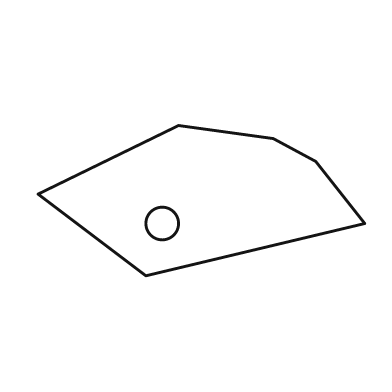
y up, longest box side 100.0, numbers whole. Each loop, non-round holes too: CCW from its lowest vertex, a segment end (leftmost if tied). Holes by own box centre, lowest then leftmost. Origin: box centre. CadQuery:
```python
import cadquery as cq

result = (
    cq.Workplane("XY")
    .moveTo(-17.0, -23.0)
    .lineTo(50.0, -7.0)
    .lineTo(35.0, 12.0)
    .lineTo(22.0, 19.0)
    .lineTo(-7.0, 23.0)
    .lineTo(-50.0, 2.0)
    .close()
    .moveTo(-12.0, -7.0)
    .circle(5.0)
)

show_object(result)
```